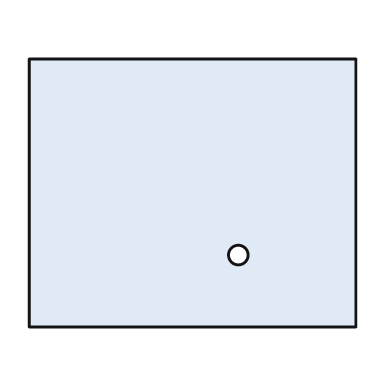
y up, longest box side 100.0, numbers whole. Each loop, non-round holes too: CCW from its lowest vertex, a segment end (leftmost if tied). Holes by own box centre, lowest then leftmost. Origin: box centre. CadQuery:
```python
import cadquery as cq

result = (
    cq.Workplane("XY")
    .moveTo(-50.0, -41.0)
    .lineTo(50.0, -41.0)
    .lineTo(50.0, 41.0)
    .lineTo(-50.0, 41.0)
    .close()
    .moveTo(14.0, -19.0)
    .circle(3.0)
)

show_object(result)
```